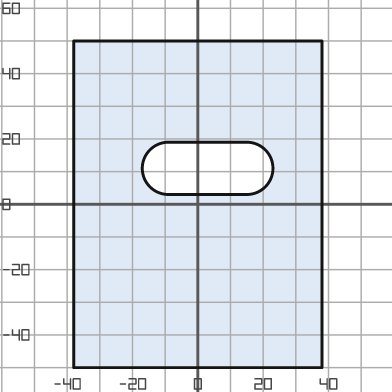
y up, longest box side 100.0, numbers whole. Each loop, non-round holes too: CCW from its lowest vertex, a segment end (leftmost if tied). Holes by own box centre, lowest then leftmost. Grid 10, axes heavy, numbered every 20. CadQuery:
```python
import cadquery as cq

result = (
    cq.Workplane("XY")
    .moveTo(-38.0, -50.0)
    .lineTo(38.0, -50.0)
    .lineTo(38.0, 50.0)
    .lineTo(-38.0, 50.0)
    .close()
    .moveTo(-9.0, 3.0)
    .lineTo(15.0, 3.0)
    .threePointArc((23.0, 11.0), (15.0, 19.0))
    .lineTo(-9.0, 19.0)
    .threePointArc((-17.0, 11.0), (-9.0, 3.0))
    .close()
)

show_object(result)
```